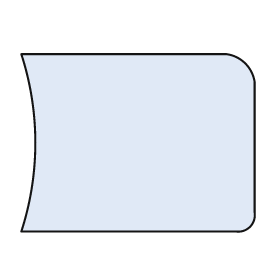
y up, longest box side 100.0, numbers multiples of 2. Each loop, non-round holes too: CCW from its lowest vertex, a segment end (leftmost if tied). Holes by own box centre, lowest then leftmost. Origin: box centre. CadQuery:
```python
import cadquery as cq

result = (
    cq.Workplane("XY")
    .moveTo(-50.0, -38.0)
    .lineTo(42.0, -38.0)
    .threePointArc((48.0, -36.0), (50.0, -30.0))
    .lineTo(50.0, 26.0)
    .threePointArc((46.0, 34.0), (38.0, 38.0))
    .lineTo(-50.0, 38.0)
    .threePointArc((-44.0, 0.0), (-50.0, -38.0))
    .close()
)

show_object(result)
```